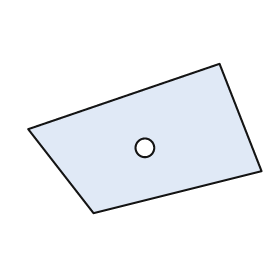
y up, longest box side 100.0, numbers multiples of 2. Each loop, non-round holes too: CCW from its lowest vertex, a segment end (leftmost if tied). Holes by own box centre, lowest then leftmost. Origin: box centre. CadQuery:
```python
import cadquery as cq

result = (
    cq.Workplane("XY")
    .moveTo(-22.0, -32.0)
    .lineTo(50.0, -14.0)
    .lineTo(32.0, 32.0)
    .lineTo(-50.0, 4.0)
    .close()
    .moveTo(0.0, -4.0)
    .circle(4.0)
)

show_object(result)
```